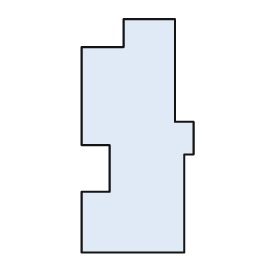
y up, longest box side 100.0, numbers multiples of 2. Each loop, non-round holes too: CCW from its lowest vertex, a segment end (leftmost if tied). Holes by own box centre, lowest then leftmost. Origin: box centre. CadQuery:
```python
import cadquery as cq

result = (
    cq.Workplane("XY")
    .moveTo(-24.0, -50.0)
    .lineTo(20.0, -50.0)
    .lineTo(20.0, -8.0)
    .lineTo(24.0, -8.0)
    .lineTo(24.0, 6.0)
    .lineTo(16.0, 6.0)
    .lineTo(16.0, 50.0)
    .lineTo(-6.0, 50.0)
    .lineTo(-6.0, 38.0)
    .lineTo(-24.0, 38.0)
    .lineTo(-24.0, -4.0)
    .lineTo(-12.0, -4.0)
    .lineTo(-12.0, -24.0)
    .lineTo(-24.0, -24.0)
    .close()
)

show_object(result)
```